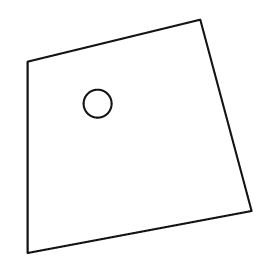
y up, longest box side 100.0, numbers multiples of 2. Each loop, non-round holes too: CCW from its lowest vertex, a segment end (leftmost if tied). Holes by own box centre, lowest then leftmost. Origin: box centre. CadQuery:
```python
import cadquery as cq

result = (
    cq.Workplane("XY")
    .moveTo(-48.0, -50.0)
    .lineTo(48.0, -32.0)
    .lineTo(26.0, 50.0)
    .lineTo(-48.0, 32.0)
    .close()
    .moveTo(-18.0, 14.0)
    .circle(6.0)
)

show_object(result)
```